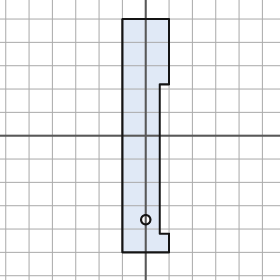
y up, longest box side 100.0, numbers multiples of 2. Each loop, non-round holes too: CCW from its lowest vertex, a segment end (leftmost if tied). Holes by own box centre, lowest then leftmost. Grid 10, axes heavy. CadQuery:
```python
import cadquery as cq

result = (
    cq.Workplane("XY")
    .moveTo(-10.0, -50.0)
    .lineTo(10.0, -50.0)
    .lineTo(10.0, -42.0)
    .lineTo(6.0, -42.0)
    .lineTo(6.0, 22.0)
    .lineTo(10.0, 22.0)
    .lineTo(10.0, 50.0)
    .lineTo(-10.0, 50.0)
    .close()
    .moveTo(0.0, -36.0)
    .circle(2.0)
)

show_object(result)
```